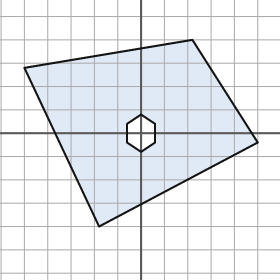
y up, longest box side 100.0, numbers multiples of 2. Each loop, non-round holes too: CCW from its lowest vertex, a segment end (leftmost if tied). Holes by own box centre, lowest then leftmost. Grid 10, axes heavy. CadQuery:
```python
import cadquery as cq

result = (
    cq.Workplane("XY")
    .moveTo(-18.0, -40.0)
    .lineTo(50.0, -4.0)
    .lineTo(22.0, 40.0)
    .lineTo(-50.0, 28.0)
    .close()
    .moveTo(0.0, -8.0)
    .lineTo(6.0, -4.0)
    .lineTo(6.0, 4.0)
    .lineTo(0.0, 8.0)
    .lineTo(-6.0, 4.0)
    .lineTo(-6.0, -4.0)
    .close()
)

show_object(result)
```